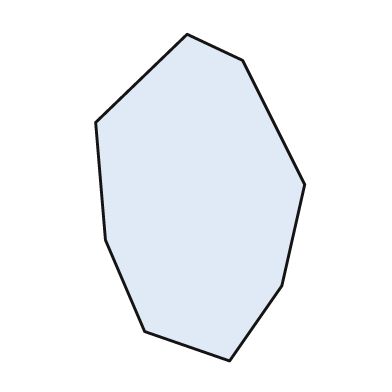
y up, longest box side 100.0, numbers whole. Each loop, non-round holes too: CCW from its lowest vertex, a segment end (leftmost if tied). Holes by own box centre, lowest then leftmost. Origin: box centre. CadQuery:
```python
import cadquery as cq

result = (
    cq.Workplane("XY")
    .moveTo(9.0, -50.0)
    .lineTo(25.0, -27.0)
    .lineTo(32.0, 4.0)
    .lineTo(13.0, 42.0)
    .lineTo(-4.0, 50.0)
    .lineTo(-32.0, 23.0)
    .lineTo(-29.0, -13.0)
    .lineTo(-17.0, -41.0)
    .close()
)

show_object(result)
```